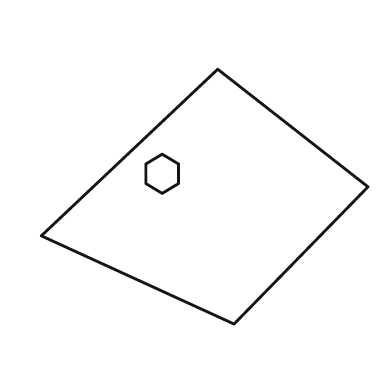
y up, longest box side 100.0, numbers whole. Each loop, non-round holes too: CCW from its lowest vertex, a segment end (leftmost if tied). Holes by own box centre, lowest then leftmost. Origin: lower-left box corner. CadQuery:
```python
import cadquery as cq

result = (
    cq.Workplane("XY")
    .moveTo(59.0, 0.0)
    .lineTo(100.0, 42.0)
    .lineTo(54.0, 78.0)
    .lineTo(0.0, 27.0)
    .close()
    .moveTo(37.0, 40.0)
    .lineTo(42.0, 43.0)
    .lineTo(42.0, 49.0)
    .lineTo(37.0, 52.0)
    .lineTo(32.0, 49.0)
    .lineTo(32.0, 43.0)
    .close()
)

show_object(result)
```